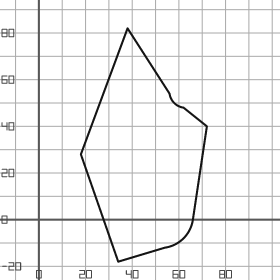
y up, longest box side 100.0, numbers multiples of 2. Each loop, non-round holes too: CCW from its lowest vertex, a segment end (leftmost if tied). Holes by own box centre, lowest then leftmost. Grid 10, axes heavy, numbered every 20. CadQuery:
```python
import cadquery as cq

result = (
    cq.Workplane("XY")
    .moveTo(34.0, -18.0)
    .lineTo(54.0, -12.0)
    .threePointArc((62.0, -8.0), (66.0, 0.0))
    .lineTo(72.0, 40.0)
    .lineTo(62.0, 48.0)
    .threePointArc((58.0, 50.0), (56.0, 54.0))
    .lineTo(38.0, 82.0)
    .lineTo(18.0, 28.0)
    .close()
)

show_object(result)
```